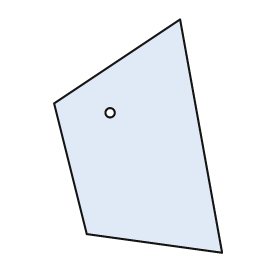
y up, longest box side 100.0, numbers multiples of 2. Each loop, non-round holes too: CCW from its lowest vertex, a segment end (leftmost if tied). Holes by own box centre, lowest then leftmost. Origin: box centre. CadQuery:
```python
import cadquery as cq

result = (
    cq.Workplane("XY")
    .moveTo(36.0, -50.0)
    .lineTo(18.0, 50.0)
    .lineTo(-36.0, 14.0)
    .lineTo(-22.0, -42.0)
    .close()
    .moveTo(-12.0, 10.0)
    .circle(2.0)
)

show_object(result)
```